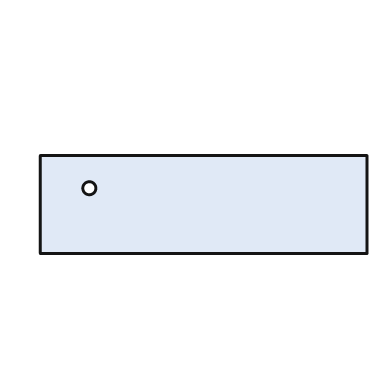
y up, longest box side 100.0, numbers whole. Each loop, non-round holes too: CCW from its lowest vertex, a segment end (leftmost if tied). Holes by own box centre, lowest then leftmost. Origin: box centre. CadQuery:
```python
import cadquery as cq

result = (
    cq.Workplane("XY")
    .moveTo(-50.0, -15.0)
    .lineTo(50.0, -15.0)
    .lineTo(50.0, 15.0)
    .lineTo(-50.0, 15.0)
    .close()
    .moveTo(-35.0, 5.0)
    .circle(2.0)
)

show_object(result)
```